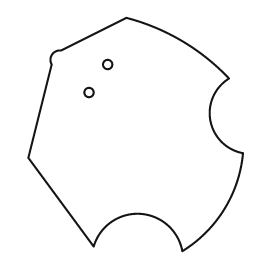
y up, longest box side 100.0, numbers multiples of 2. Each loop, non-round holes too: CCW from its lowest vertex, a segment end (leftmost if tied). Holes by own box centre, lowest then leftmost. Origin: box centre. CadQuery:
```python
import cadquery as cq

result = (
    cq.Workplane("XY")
    .moveTo(20.0, -50.0)
    .threePointArc((38.0, -32.0), (46.0, -8.0))
    .threePointArc((32.0, 6.0), (40.0, 24.0))
    .threePointArc((20.0, 40.0), (-4.0, 50.0))
    .lineTo(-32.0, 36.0)
    .threePointArc((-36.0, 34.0), (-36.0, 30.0))
    .lineTo(-46.0, -10.0)
    .lineTo(-18.0, -48.0)
    .threePointArc((2.0, -34.0), (20.0, -50.0))
    .close()
    .moveTo(-20.0, 18.0)
    .circle(2.0)
    .moveTo(-12.0, 30.0)
    .circle(2.0)
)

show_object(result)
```